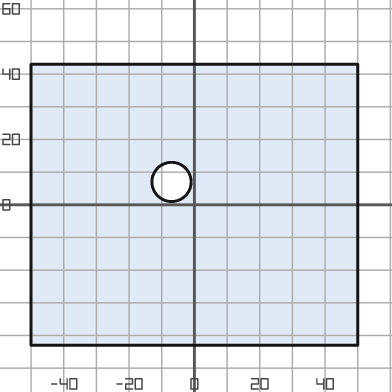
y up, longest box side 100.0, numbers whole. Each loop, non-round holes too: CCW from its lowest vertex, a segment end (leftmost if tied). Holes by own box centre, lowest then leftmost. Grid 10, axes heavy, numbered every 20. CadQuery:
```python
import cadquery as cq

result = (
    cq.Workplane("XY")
    .moveTo(-50.0, -43.0)
    .lineTo(50.0, -43.0)
    .lineTo(50.0, 43.0)
    .lineTo(-50.0, 43.0)
    .close()
    .moveTo(-7.0, 7.0)
    .circle(6.0)
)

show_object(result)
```